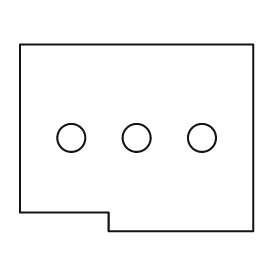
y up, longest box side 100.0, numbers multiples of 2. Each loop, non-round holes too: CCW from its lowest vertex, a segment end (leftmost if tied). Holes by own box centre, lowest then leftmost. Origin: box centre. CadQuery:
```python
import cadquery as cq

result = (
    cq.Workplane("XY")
    .moveTo(-12.0, -40.0)
    .lineTo(50.0, -40.0)
    .lineTo(50.0, 40.0)
    .lineTo(-50.0, 40.0)
    .lineTo(-50.0, -32.0)
    .lineTo(-12.0, -32.0)
    .close()
    .moveTo(-28.0, 0.0)
    .circle(6.0)
    .moveTo(0.0, 0.0)
    .circle(6.0)
    .moveTo(28.0, 0.0)
    .circle(6.0)
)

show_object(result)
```